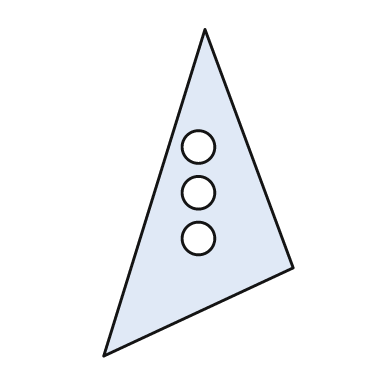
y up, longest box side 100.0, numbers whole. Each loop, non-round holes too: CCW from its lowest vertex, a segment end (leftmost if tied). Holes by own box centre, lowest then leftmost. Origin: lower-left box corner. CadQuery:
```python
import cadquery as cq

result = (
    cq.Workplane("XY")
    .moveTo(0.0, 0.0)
    .lineTo(58.0, 27.0)
    .lineTo(31.0, 100.0)
    .close()
    .moveTo(29.0, 36.0)
    .circle(5.0)
    .moveTo(29.0, 50.0)
    .circle(5.0)
    .moveTo(29.0, 64.0)
    .circle(5.0)
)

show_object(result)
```